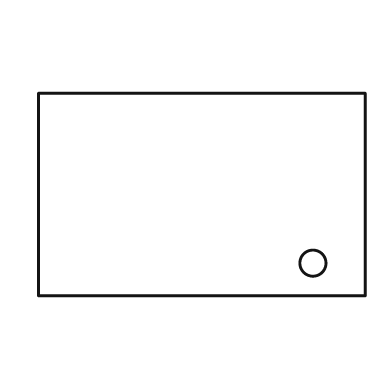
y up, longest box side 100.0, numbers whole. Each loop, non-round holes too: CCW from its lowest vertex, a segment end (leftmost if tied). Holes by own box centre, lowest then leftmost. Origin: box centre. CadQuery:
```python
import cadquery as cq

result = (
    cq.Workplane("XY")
    .moveTo(-50.0, -31.0)
    .lineTo(50.0, -31.0)
    .lineTo(50.0, 31.0)
    .lineTo(-50.0, 31.0)
    .close()
    .moveTo(34.0, -21.0)
    .circle(4.0)
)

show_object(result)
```